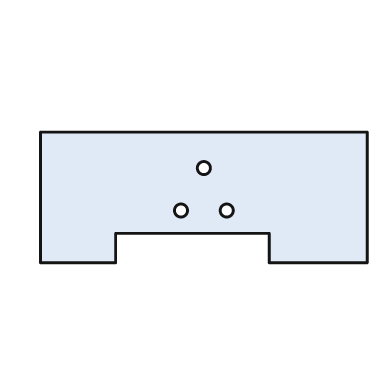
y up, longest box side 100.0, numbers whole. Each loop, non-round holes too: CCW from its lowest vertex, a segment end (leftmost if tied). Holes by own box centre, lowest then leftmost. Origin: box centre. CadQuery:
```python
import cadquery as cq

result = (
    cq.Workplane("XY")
    .moveTo(-50.0, -20.0)
    .lineTo(-27.0, -20.0)
    .lineTo(-27.0, -11.0)
    .lineTo(20.0, -11.0)
    .lineTo(20.0, -20.0)
    .lineTo(50.0, -20.0)
    .lineTo(50.0, 20.0)
    .lineTo(-50.0, 20.0)
    .close()
    .moveTo(-7.0, -4.0)
    .circle(2.0)
    .moveTo(7.0, -4.0)
    .circle(2.0)
    .moveTo(0.0, 9.0)
    .circle(2.0)
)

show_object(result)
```